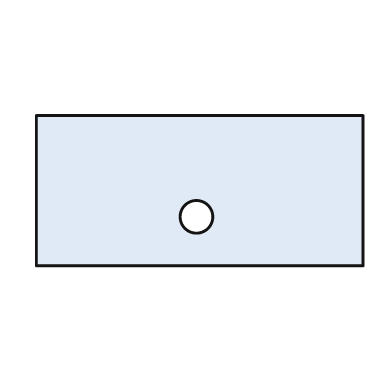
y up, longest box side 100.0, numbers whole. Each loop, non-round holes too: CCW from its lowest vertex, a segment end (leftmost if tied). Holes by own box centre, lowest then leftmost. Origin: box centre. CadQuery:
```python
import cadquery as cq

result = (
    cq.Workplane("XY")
    .moveTo(-50.0, -23.0)
    .lineTo(50.0, -23.0)
    .lineTo(50.0, 23.0)
    .lineTo(-50.0, 23.0)
    .close()
    .moveTo(-1.0, -8.0)
    .circle(5.0)
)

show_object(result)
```